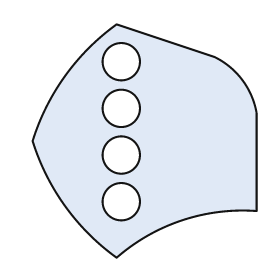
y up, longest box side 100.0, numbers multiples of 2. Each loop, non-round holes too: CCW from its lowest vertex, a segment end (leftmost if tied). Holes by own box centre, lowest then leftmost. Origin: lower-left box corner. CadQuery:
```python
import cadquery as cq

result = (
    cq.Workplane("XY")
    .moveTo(36.0, 0.0)
    .threePointArc((64.0, 16.0), (96.0, 20.0))
    .lineTo(96.0, 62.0)
    .threePointArc((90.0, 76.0), (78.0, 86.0))
    .lineTo(36.0, 100.0)
    .threePointArc((14.0, 78.0), (0.0, 50.0))
    .threePointArc((14.0, 22.0), (36.0, 0.0))
    .close()
    .moveTo(38.0, 24.0)
    .circle(8.0)
    .moveTo(38.0, 44.0)
    .circle(8.0)
    .moveTo(38.0, 64.0)
    .circle(8.0)
    .moveTo(38.0, 84.0)
    .circle(8.0)
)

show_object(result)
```